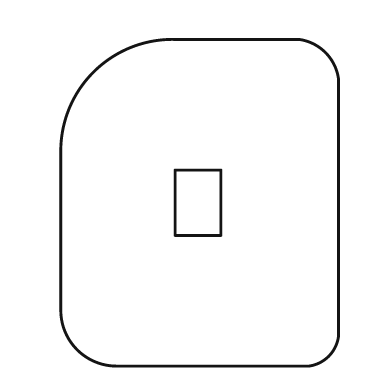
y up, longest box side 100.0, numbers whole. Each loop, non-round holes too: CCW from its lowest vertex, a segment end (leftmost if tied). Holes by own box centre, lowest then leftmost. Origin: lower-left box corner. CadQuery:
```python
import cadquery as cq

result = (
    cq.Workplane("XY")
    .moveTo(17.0, 0.0)
    .lineTo(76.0, 0.0)
    .threePointArc((82.0, 3.0), (85.0, 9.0))
    .lineTo(85.0, 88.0)
    .threePointArc((81.0, 96.0), (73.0, 100.0))
    .lineTo(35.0, 100.0)
    .threePointArc((10.0, 90.0), (0.0, 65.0))
    .lineTo(0.0, 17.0)
    .threePointArc((5.0, 5.0), (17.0, 0.0))
    .close()
    .moveTo(35.0, 40.0)
    .lineTo(49.0, 40.0)
    .lineTo(49.0, 60.0)
    .lineTo(35.0, 60.0)
    .close()
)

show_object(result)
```